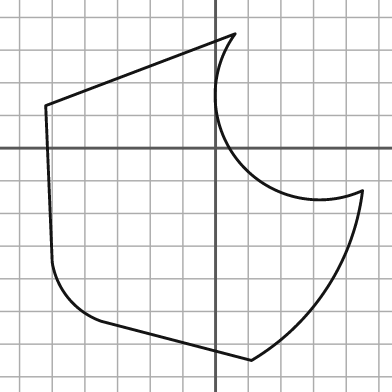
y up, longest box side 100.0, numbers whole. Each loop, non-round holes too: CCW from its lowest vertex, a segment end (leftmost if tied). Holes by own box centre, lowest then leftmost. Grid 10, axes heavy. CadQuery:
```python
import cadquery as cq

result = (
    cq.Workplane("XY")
    .moveTo(11.0, -65.0)
    .threePointArc((34.0, -43.0), (45.0, -13.0))
    .threePointArc((7.0, -4.0), (6.0, 35.0))
    .lineTo(-52.0, 13.0)
    .lineTo(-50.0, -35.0)
    .threePointArc((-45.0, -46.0), (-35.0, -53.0))
    .close()
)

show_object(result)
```